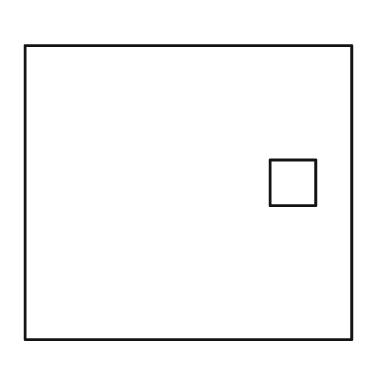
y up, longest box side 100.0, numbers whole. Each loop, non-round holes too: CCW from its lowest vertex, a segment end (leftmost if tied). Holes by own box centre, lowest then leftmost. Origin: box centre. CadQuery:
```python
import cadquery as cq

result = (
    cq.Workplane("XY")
    .moveTo(-50.0, -45.0)
    .lineTo(50.0, -45.0)
    .lineTo(50.0, 45.0)
    .lineTo(-50.0, 45.0)
    .close()
    .moveTo(25.0, -4.0)
    .lineTo(39.0, -4.0)
    .lineTo(39.0, 10.0)
    .lineTo(25.0, 10.0)
    .close()
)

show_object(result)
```